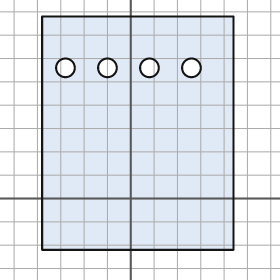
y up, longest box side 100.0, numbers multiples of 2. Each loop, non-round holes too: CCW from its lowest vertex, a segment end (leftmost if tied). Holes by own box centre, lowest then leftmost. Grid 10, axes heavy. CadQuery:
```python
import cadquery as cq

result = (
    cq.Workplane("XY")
    .moveTo(-38.0, -22.0)
    .lineTo(44.0, -22.0)
    .lineTo(44.0, 78.0)
    .lineTo(-38.0, 78.0)
    .close()
    .moveTo(-28.0, 56.0)
    .circle(4.0)
    .moveTo(-10.0, 56.0)
    .circle(4.0)
    .moveTo(8.0, 56.0)
    .circle(4.0)
    .moveTo(26.0, 56.0)
    .circle(4.0)
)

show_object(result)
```